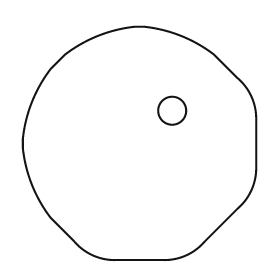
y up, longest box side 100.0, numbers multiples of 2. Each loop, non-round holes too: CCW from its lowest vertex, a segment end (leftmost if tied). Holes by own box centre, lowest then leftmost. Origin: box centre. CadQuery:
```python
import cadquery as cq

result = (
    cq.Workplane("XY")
    .moveTo(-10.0, -50.0)
    .lineTo(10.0, -50.0)
    .threePointArc((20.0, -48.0), (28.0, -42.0))
    .lineTo(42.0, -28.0)
    .threePointArc((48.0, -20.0), (50.0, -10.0))
    .lineTo(50.0, 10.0)
    .threePointArc((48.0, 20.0), (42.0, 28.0))
    .lineTo(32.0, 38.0)
    .threePointArc((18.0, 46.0), (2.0, 50.0))
    .lineTo(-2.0, 50.0)
    .threePointArc((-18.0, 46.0), (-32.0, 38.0))
    .lineTo(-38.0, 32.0)
    .threePointArc((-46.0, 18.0), (-50.0, 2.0))
    .lineTo(-50.0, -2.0)
    .threePointArc((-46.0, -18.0), (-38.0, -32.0))
    .lineTo(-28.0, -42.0)
    .threePointArc((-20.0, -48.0), (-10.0, -50.0))
    .close()
    .moveTo(14.0, 14.0)
    .circle(6.0)
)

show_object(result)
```